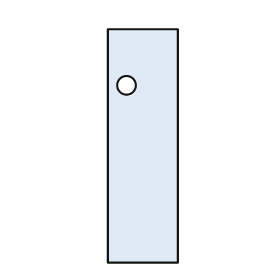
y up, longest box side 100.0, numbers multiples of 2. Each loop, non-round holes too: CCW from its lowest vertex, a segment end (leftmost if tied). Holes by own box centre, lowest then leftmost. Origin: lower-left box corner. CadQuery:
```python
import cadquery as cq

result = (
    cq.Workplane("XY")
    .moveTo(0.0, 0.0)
    .lineTo(30.0, 0.0)
    .lineTo(30.0, 100.0)
    .lineTo(0.0, 100.0)
    .close()
    .moveTo(8.0, 76.0)
    .circle(4.0)
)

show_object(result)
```